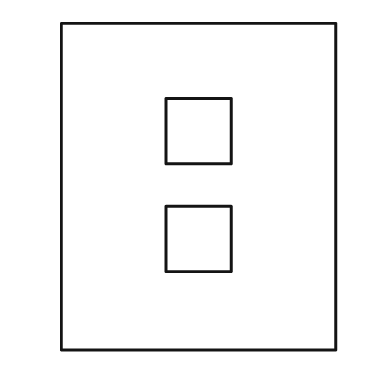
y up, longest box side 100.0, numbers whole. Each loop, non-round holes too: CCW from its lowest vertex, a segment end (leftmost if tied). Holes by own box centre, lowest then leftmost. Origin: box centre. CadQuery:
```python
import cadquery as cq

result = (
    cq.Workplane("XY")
    .moveTo(-42.0, -50.0)
    .lineTo(42.0, -50.0)
    .lineTo(42.0, 50.0)
    .lineTo(-42.0, 50.0)
    .close()
    .moveTo(-10.0, -26.0)
    .lineTo(10.0, -26.0)
    .lineTo(10.0, -6.0)
    .lineTo(-10.0, -6.0)
    .close()
    .moveTo(-10.0, 7.0)
    .lineTo(10.0, 7.0)
    .lineTo(10.0, 27.0)
    .lineTo(-10.0, 27.0)
    .close()
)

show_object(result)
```